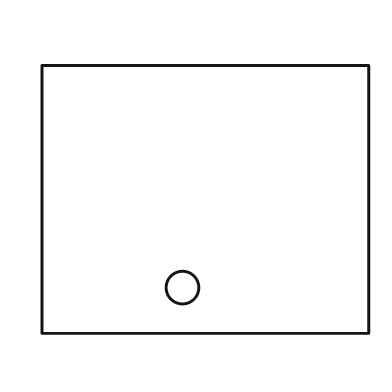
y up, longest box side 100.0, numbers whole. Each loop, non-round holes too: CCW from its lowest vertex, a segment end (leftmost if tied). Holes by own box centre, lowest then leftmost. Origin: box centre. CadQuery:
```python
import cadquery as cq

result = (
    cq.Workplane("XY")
    .moveTo(-50.0, -41.0)
    .lineTo(50.0, -41.0)
    .lineTo(50.0, 41.0)
    .lineTo(-50.0, 41.0)
    .close()
    .moveTo(-7.0, -27.0)
    .circle(5.0)
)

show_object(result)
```